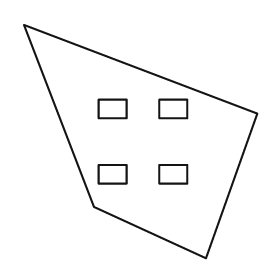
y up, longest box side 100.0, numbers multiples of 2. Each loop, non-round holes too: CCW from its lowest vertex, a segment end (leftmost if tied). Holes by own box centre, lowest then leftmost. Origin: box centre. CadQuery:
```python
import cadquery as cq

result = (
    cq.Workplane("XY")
    .moveTo(28.0, -50.0)
    .lineTo(50.0, 12.0)
    .lineTo(-50.0, 50.0)
    .lineTo(-20.0, -28.0)
    .close()
    .moveTo(-18.0, -18.0)
    .lineTo(-6.0, -18.0)
    .lineTo(-6.0, -10.0)
    .lineTo(-18.0, -10.0)
    .close()
    .moveTo(8.0, -18.0)
    .lineTo(20.0, -18.0)
    .lineTo(20.0, -10.0)
    .lineTo(8.0, -10.0)
    .close()
    .moveTo(-18.0, 10.0)
    .lineTo(-6.0, 10.0)
    .lineTo(-6.0, 18.0)
    .lineTo(-18.0, 18.0)
    .close()
    .moveTo(8.0, 10.0)
    .lineTo(20.0, 10.0)
    .lineTo(20.0, 18.0)
    .lineTo(8.0, 18.0)
    .close()
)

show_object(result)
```